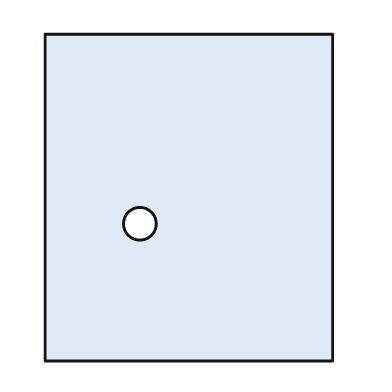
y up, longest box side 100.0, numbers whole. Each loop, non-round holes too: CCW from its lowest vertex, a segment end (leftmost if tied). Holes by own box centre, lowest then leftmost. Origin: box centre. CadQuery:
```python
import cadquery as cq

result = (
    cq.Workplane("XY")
    .moveTo(-44.0, -50.0)
    .lineTo(44.0, -50.0)
    .lineTo(44.0, 50.0)
    .lineTo(-44.0, 50.0)
    .close()
    .moveTo(-15.0, -8.0)
    .circle(5.0)
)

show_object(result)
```